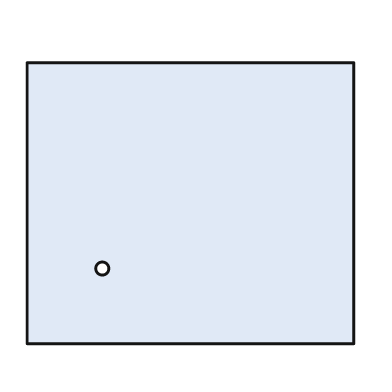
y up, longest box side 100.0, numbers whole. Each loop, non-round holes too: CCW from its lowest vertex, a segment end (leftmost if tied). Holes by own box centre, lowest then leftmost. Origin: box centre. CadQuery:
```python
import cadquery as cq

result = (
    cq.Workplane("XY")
    .moveTo(-50.0, -43.0)
    .lineTo(50.0, -43.0)
    .lineTo(50.0, 43.0)
    .lineTo(-50.0, 43.0)
    .close()
    .moveTo(-27.0, -20.0)
    .circle(2.0)
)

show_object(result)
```